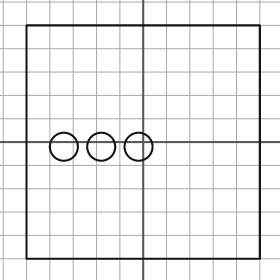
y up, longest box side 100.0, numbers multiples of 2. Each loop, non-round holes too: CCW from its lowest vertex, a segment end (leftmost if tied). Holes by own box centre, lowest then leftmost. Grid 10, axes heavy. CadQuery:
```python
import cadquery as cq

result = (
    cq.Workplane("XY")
    .moveTo(-50.0, -50.0)
    .lineTo(50.0, -50.0)
    .lineTo(50.0, 50.0)
    .lineTo(-50.0, 50.0)
    .close()
    .moveTo(-34.0, -2.0)
    .circle(6.0)
    .moveTo(-18.0, -2.0)
    .circle(6.0)
    .moveTo(-2.0, -2.0)
    .circle(6.0)
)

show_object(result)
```